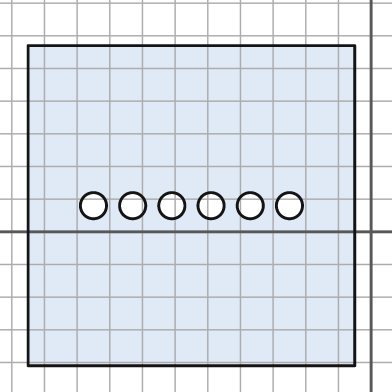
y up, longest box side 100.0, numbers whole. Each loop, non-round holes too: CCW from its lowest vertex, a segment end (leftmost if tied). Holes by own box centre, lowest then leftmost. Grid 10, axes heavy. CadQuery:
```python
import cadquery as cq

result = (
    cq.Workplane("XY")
    .moveTo(-105.0, -41.0)
    .lineTo(-5.0, -41.0)
    .lineTo(-5.0, 57.0)
    .lineTo(-105.0, 57.0)
    .close()
    .moveTo(-85.0, 8.0)
    .circle(4.0)
    .moveTo(-73.0, 8.0)
    .circle(4.0)
    .moveTo(-61.0, 8.0)
    .circle(4.0)
    .moveTo(-49.0, 8.0)
    .circle(4.0)
    .moveTo(-37.0, 8.0)
    .circle(4.0)
    .moveTo(-25.0, 8.0)
    .circle(4.0)
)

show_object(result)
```